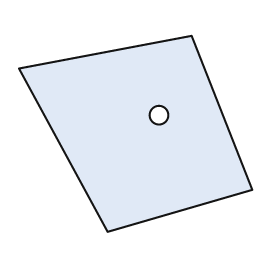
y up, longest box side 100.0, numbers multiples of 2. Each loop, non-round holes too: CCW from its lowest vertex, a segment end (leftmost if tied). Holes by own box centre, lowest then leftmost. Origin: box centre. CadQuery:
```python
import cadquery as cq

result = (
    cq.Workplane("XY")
    .moveTo(-12.0, -42.0)
    .lineTo(50.0, -24.0)
    .lineTo(24.0, 42.0)
    .lineTo(-50.0, 28.0)
    .close()
    .moveTo(10.0, 8.0)
    .circle(4.0)
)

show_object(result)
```